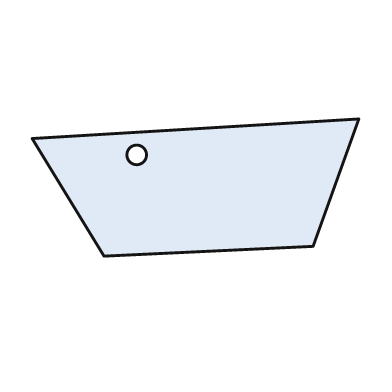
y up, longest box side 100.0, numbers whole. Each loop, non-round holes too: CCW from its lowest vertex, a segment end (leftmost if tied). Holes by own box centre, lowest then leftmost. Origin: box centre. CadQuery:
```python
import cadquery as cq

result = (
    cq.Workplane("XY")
    .moveTo(-28.0, -21.0)
    .lineTo(36.0, -18.0)
    .lineTo(50.0, 21.0)
    .lineTo(-50.0, 15.0)
    .close()
    .moveTo(-18.0, 10.0)
    .circle(3.0)
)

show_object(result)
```